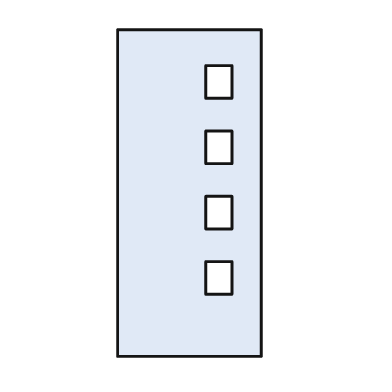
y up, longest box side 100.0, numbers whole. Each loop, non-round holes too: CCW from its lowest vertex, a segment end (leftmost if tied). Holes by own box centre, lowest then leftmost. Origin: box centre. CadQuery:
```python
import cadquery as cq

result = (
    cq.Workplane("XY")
    .moveTo(-22.0, -50.0)
    .lineTo(22.0, -50.0)
    .lineTo(22.0, 50.0)
    .lineTo(-22.0, 50.0)
    .close()
    .moveTo(5.0, -31.0)
    .lineTo(13.0, -31.0)
    .lineTo(13.0, -21.0)
    .lineTo(5.0, -21.0)
    .close()
    .moveTo(5.0, -11.0)
    .lineTo(13.0, -11.0)
    .lineTo(13.0, -1.0)
    .lineTo(5.0, -1.0)
    .close()
    .moveTo(5.0, 9.0)
    .lineTo(13.0, 9.0)
    .lineTo(13.0, 19.0)
    .lineTo(5.0, 19.0)
    .close()
    .moveTo(5.0, 29.0)
    .lineTo(13.0, 29.0)
    .lineTo(13.0, 39.0)
    .lineTo(5.0, 39.0)
    .close()
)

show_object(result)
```